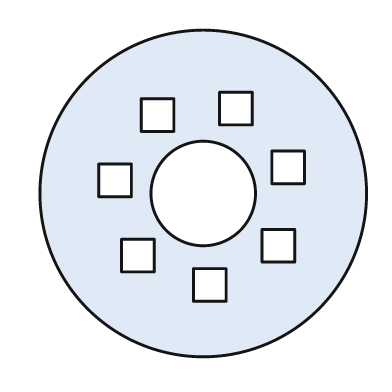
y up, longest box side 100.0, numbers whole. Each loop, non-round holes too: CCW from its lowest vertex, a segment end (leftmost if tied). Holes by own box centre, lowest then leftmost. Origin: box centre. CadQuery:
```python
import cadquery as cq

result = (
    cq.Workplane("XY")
    .moveTo(0.0, 0.0)
    .circle(50.0)
    .moveTo(-3.0, -33.0)
    .lineTo(7.0, -33.0)
    .lineTo(7.0, -23.0)
    .lineTo(-3.0, -23.0)
    .close()
    .moveTo(-25.0, -24.0)
    .lineTo(-15.0, -24.0)
    .lineTo(-15.0, -14.0)
    .lineTo(-25.0, -14.0)
    .close()
    .moveTo(18.0, -21.0)
    .lineTo(28.0, -21.0)
    .lineTo(28.0, -11.0)
    .lineTo(18.0, -11.0)
    .close()
    .moveTo(0.0, 0.0)
    .circle(16.0)
    .moveTo(-32.0, -1.0)
    .lineTo(-22.0, -1.0)
    .lineTo(-22.0, 9.0)
    .lineTo(-32.0, 9.0)
    .close()
    .moveTo(21.0, 3.0)
    .lineTo(31.0, 3.0)
    .lineTo(31.0, 13.0)
    .lineTo(21.0, 13.0)
    .close()
    .moveTo(-19.0, 19.0)
    .lineTo(-9.0, 19.0)
    .lineTo(-9.0, 29.0)
    .lineTo(-19.0, 29.0)
    .close()
    .moveTo(5.0, 21.0)
    .lineTo(15.0, 21.0)
    .lineTo(15.0, 31.0)
    .lineTo(5.0, 31.0)
    .close()
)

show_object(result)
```